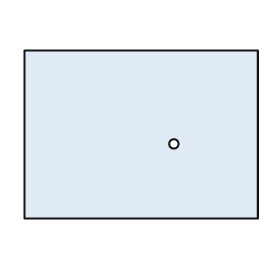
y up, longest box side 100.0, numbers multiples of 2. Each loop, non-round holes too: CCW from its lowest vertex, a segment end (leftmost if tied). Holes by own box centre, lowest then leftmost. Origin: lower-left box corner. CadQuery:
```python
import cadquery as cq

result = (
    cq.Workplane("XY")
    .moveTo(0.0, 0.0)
    .lineTo(100.0, 0.0)
    .lineTo(100.0, 72.0)
    .lineTo(0.0, 72.0)
    .close()
    .moveTo(64.0, 32.0)
    .circle(2.0)
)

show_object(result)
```